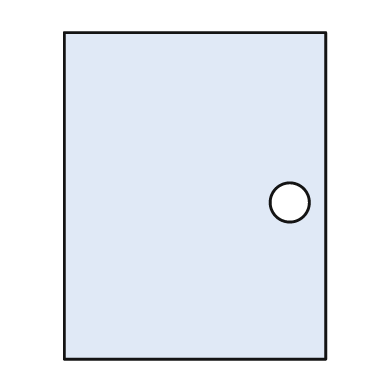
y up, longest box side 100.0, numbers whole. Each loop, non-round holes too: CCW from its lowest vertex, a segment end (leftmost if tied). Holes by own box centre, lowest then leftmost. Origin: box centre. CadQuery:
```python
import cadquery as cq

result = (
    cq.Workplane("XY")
    .moveTo(-40.0, -50.0)
    .lineTo(40.0, -50.0)
    .lineTo(40.0, 50.0)
    .lineTo(-40.0, 50.0)
    .close()
    .moveTo(29.0, -2.0)
    .circle(6.0)
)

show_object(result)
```